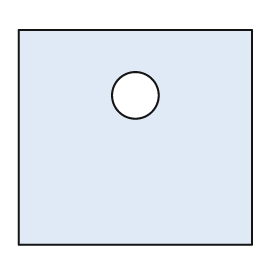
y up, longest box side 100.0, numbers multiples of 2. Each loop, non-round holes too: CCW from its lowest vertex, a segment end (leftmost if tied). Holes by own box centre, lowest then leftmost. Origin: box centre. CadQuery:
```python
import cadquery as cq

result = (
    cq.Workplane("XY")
    .moveTo(-50.0, -46.0)
    .lineTo(50.0, -46.0)
    .lineTo(50.0, 46.0)
    .lineTo(-50.0, 46.0)
    .close()
    .moveTo(0.0, 18.0)
    .circle(10.0)
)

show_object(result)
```